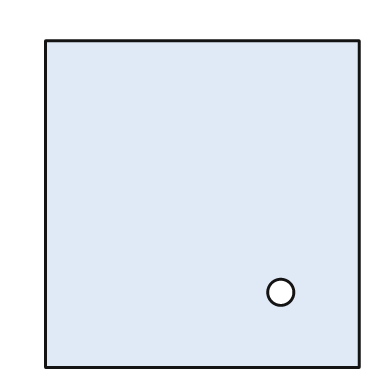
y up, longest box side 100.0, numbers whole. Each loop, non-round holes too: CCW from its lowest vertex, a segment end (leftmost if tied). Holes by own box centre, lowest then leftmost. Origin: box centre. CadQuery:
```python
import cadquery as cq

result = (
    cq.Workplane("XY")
    .moveTo(-48.0, -50.0)
    .lineTo(48.0, -50.0)
    .lineTo(48.0, 50.0)
    .lineTo(-48.0, 50.0)
    .close()
    .moveTo(24.0, -27.0)
    .circle(4.0)
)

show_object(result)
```